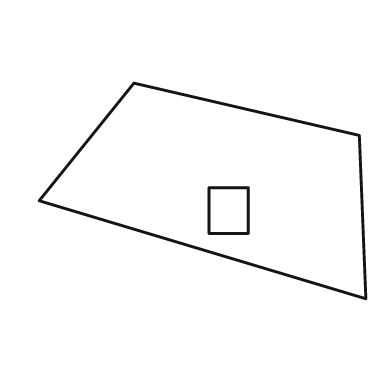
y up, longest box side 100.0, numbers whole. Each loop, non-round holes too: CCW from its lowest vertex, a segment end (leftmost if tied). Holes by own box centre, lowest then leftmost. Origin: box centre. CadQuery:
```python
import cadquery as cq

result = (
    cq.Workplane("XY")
    .moveTo(50.0, -33.0)
    .lineTo(48.0, 17.0)
    .lineTo(-21.0, 33.0)
    .lineTo(-50.0, -3.0)
    .close()
    .moveTo(2.0, -13.0)
    .lineTo(14.0, -13.0)
    .lineTo(14.0, 1.0)
    .lineTo(2.0, 1.0)
    .close()
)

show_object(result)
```